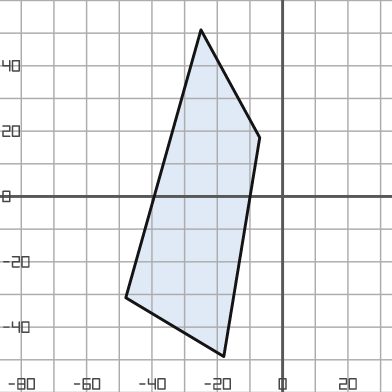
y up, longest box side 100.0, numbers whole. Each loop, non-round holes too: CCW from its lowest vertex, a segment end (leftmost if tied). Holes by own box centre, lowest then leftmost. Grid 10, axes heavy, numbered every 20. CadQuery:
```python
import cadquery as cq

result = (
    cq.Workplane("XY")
    .moveTo(-18.0, -49.0)
    .lineTo(-7.0, 18.0)
    .lineTo(-25.0, 51.0)
    .lineTo(-48.0, -31.0)
    .close()
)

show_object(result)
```